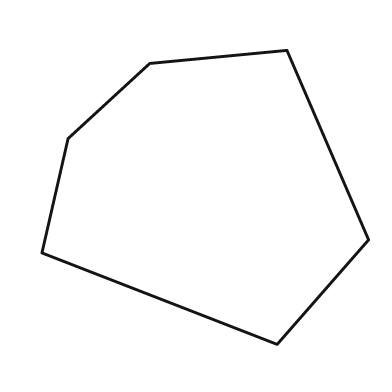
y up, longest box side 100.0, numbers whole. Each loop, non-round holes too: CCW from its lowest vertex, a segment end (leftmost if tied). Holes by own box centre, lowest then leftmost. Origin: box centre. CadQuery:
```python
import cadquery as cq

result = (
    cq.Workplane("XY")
    .moveTo(22.0, -45.0)
    .lineTo(50.0, -13.0)
    .lineTo(25.0, 45.0)
    .lineTo(-17.0, 41.0)
    .lineTo(-42.0, 18.0)
    .lineTo(-50.0, -17.0)
    .close()
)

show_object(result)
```